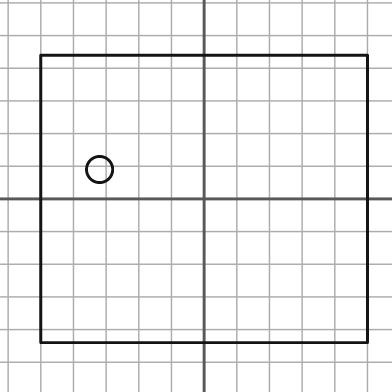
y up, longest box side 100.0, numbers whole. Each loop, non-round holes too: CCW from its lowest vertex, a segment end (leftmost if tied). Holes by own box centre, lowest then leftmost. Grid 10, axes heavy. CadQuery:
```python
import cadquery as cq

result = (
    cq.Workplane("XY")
    .moveTo(-50.0, -44.0)
    .lineTo(50.0, -44.0)
    .lineTo(50.0, 44.0)
    .lineTo(-50.0, 44.0)
    .close()
    .moveTo(-32.0, 9.0)
    .circle(4.0)
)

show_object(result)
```